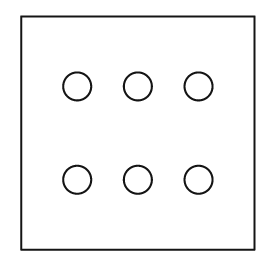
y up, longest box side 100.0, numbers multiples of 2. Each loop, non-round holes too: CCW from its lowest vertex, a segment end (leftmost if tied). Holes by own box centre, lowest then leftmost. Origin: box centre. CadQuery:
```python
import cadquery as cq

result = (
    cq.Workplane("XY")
    .moveTo(-50.0, -50.0)
    .lineTo(50.0, -50.0)
    .lineTo(50.0, 50.0)
    .lineTo(-50.0, 50.0)
    .close()
    .moveTo(-26.0, -20.0)
    .circle(6.0)
    .moveTo(0.0, -20.0)
    .circle(6.0)
    .moveTo(26.0, -20.0)
    .circle(6.0)
    .moveTo(-26.0, 20.0)
    .circle(6.0)
    .moveTo(0.0, 20.0)
    .circle(6.0)
    .moveTo(26.0, 20.0)
    .circle(6.0)
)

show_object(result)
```